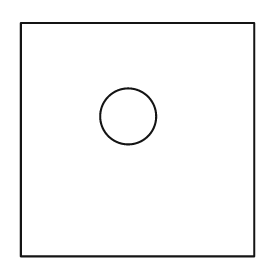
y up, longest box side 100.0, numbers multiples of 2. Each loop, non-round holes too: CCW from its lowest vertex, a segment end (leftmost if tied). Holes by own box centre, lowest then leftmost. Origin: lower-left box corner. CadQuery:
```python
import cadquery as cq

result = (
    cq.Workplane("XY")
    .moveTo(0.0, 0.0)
    .lineTo(100.0, 0.0)
    .lineTo(100.0, 100.0)
    .lineTo(0.0, 100.0)
    .close()
    .moveTo(46.0, 60.0)
    .circle(12.0)
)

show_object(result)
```